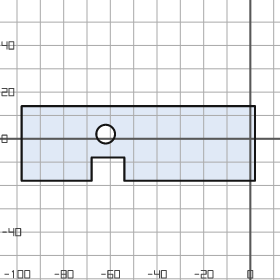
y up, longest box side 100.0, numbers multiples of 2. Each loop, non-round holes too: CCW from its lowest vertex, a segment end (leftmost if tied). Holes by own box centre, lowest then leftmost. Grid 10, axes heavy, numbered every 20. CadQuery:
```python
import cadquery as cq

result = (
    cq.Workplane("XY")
    .moveTo(-98.0, -18.0)
    .lineTo(-68.0, -18.0)
    .lineTo(-68.0, -8.0)
    .lineTo(-54.0, -8.0)
    .lineTo(-54.0, -18.0)
    .lineTo(2.0, -18.0)
    .lineTo(2.0, 14.0)
    .lineTo(-98.0, 14.0)
    .close()
    .moveTo(-62.0, 2.0)
    .circle(4.0)
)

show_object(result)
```